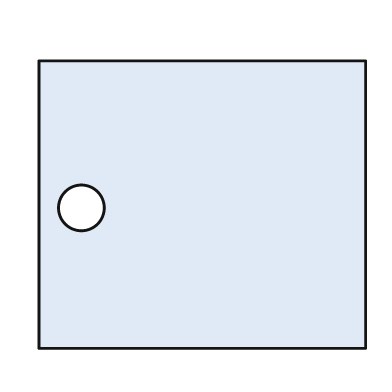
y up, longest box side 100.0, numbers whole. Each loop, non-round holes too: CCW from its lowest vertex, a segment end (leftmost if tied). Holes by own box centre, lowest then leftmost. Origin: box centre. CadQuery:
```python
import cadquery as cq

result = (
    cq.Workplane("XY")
    .moveTo(-50.0, -44.0)
    .lineTo(50.0, -44.0)
    .lineTo(50.0, 44.0)
    .lineTo(-50.0, 44.0)
    .close()
    .moveTo(-37.0, -1.0)
    .circle(7.0)
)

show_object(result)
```